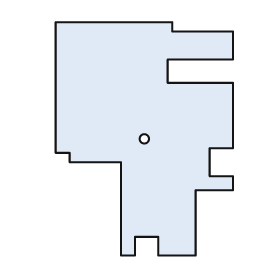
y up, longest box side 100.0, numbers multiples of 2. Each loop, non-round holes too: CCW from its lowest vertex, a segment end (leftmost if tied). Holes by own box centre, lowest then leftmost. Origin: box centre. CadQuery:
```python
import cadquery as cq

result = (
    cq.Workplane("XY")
    .moveTo(-10.0, -50.0)
    .lineTo(-4.0, -50.0)
    .lineTo(-4.0, -42.0)
    .lineTo(6.0, -42.0)
    .lineTo(6.0, -50.0)
    .lineTo(22.0, -50.0)
    .lineTo(22.0, -22.0)
    .lineTo(38.0, -22.0)
    .lineTo(38.0, -16.0)
    .lineTo(28.0, -16.0)
    .lineTo(28.0, -4.0)
    .lineTo(38.0, -4.0)
    .lineTo(38.0, 24.0)
    .lineTo(10.0, 24.0)
    .lineTo(10.0, 34.0)
    .lineTo(38.0, 34.0)
    .lineTo(38.0, 46.0)
    .lineTo(12.0, 46.0)
    .lineTo(12.0, 50.0)
    .lineTo(-38.0, 50.0)
    .lineTo(-38.0, -6.0)
    .lineTo(-32.0, -6.0)
    .lineTo(-32.0, -10.0)
    .lineTo(-10.0, -10.0)
    .close()
    .moveTo(0.0, 0.0)
    .circle(2.0)
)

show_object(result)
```